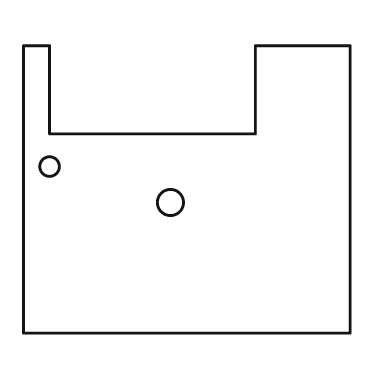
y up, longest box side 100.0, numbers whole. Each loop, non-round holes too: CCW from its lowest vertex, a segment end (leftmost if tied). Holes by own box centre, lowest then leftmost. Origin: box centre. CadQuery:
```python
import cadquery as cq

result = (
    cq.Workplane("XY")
    .moveTo(-50.0, -44.0)
    .lineTo(50.0, -44.0)
    .lineTo(50.0, 44.0)
    .lineTo(21.0, 44.0)
    .lineTo(21.0, 17.0)
    .lineTo(-42.0, 17.0)
    .lineTo(-42.0, 44.0)
    .lineTo(-50.0, 44.0)
    .close()
    .moveTo(-5.0, -4.0)
    .circle(4.0)
    .moveTo(-42.0, 7.0)
    .circle(3.0)
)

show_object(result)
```